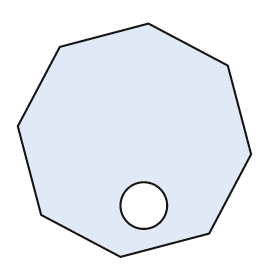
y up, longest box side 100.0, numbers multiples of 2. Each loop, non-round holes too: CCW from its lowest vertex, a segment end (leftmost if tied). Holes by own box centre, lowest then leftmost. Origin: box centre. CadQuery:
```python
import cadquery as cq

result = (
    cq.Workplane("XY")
    .moveTo(-6.0, -50.0)
    .lineTo(32.0, -40.0)
    .lineTo(50.0, -6.0)
    .lineTo(40.0, 32.0)
    .lineTo(6.0, 50.0)
    .lineTo(-32.0, 40.0)
    .lineTo(-50.0, 6.0)
    .lineTo(-40.0, -32.0)
    .close()
    .moveTo(4.0, -28.0)
    .circle(10.0)
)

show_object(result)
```